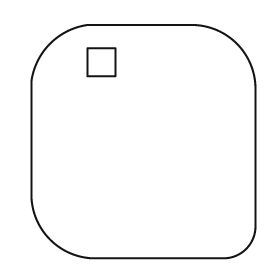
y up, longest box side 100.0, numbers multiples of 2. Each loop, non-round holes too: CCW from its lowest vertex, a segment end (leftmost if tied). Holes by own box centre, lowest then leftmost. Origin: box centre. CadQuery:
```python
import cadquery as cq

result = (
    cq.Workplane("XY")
    .moveTo(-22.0, -50.0)
    .lineTo(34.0, -50.0)
    .threePointArc((44.0, -46.0), (48.0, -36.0))
    .lineTo(48.0, 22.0)
    .threePointArc((40.0, 42.0), (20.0, 50.0))
    .lineTo(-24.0, 50.0)
    .threePointArc((-40.0, 42.0), (-48.0, 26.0))
    .lineTo(-48.0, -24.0)
    .threePointArc((-40.0, -42.0), (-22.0, -50.0))
    .close()
    .moveTo(-24.0, 28.0)
    .lineTo(-12.0, 28.0)
    .lineTo(-12.0, 40.0)
    .lineTo(-24.0, 40.0)
    .close()
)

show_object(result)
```